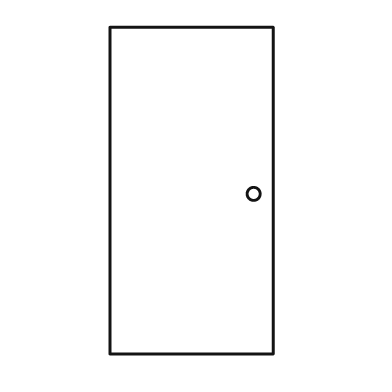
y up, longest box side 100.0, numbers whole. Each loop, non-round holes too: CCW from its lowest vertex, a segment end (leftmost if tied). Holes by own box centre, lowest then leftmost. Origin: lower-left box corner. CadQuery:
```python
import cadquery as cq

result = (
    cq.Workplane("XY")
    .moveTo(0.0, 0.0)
    .lineTo(50.0, 0.0)
    .lineTo(50.0, 100.0)
    .lineTo(0.0, 100.0)
    .close()
    .moveTo(44.0, 49.0)
    .circle(2.0)
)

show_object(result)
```